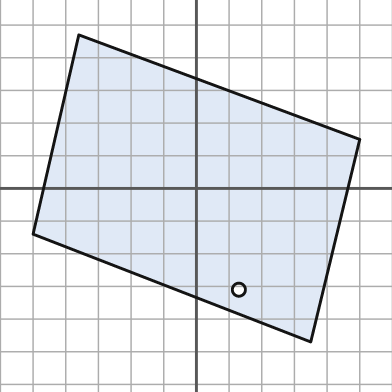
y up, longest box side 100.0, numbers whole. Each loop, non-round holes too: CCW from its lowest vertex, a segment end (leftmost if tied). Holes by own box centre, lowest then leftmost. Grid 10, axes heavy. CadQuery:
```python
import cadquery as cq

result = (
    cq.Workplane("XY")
    .moveTo(35.0, -47.0)
    .lineTo(50.0, 15.0)
    .lineTo(-36.0, 47.0)
    .lineTo(-50.0, -14.0)
    .close()
    .moveTo(13.0, -31.0)
    .circle(2.0)
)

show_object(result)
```